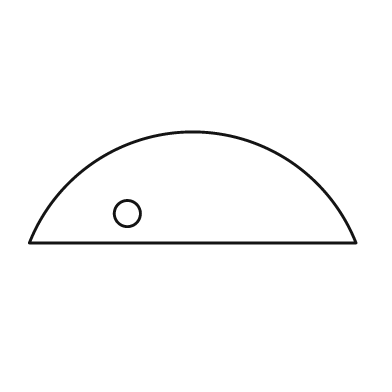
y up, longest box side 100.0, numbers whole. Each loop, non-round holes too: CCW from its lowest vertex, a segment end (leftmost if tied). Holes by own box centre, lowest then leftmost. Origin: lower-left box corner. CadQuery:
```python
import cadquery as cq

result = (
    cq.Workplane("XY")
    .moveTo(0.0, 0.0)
    .lineTo(100.0, 0.0)
    .threePointArc((50.0, 34.0), (0.0, 0.0))
    .close()
    .moveTo(30.0, 9.0)
    .circle(4.0)
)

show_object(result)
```